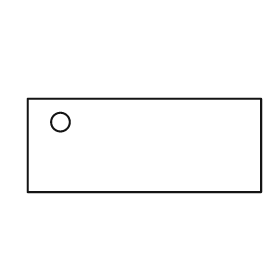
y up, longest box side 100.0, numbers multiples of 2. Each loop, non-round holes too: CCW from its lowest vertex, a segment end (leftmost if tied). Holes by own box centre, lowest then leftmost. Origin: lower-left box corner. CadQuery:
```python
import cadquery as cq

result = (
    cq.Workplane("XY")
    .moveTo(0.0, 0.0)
    .lineTo(100.0, 0.0)
    .lineTo(100.0, 40.0)
    .lineTo(0.0, 40.0)
    .close()
    .moveTo(14.0, 30.0)
    .circle(4.0)
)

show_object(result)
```